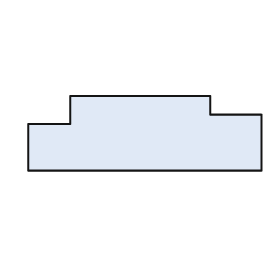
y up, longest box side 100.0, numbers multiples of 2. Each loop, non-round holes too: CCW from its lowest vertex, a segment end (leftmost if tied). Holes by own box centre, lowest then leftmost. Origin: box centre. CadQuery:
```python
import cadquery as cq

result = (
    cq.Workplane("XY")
    .moveTo(-50.0, -16.0)
    .lineTo(50.0, -16.0)
    .lineTo(50.0, 8.0)
    .lineTo(28.0, 8.0)
    .lineTo(28.0, 16.0)
    .lineTo(-32.0, 16.0)
    .lineTo(-32.0, 4.0)
    .lineTo(-50.0, 4.0)
    .close()
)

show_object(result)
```